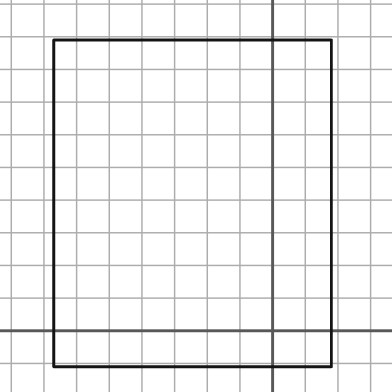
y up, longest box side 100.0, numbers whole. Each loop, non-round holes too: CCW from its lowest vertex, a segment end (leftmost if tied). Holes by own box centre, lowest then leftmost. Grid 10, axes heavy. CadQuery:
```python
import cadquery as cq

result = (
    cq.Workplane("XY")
    .moveTo(-67.0, -11.0)
    .lineTo(18.0, -11.0)
    .lineTo(18.0, 89.0)
    .lineTo(-67.0, 89.0)
    .close()
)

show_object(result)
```